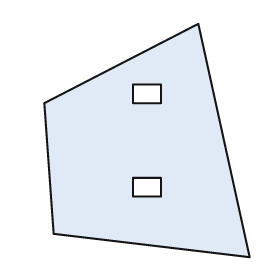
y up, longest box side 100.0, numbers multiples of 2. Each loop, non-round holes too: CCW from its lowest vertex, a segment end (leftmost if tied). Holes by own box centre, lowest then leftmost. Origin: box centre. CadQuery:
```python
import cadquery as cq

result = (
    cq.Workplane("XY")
    .moveTo(44.0, -50.0)
    .lineTo(22.0, 50.0)
    .lineTo(-44.0, 16.0)
    .lineTo(-40.0, -40.0)
    .close()
    .moveTo(-6.0, -24.0)
    .lineTo(6.0, -24.0)
    .lineTo(6.0, -16.0)
    .lineTo(-6.0, -16.0)
    .close()
    .moveTo(-6.0, 16.0)
    .lineTo(6.0, 16.0)
    .lineTo(6.0, 24.0)
    .lineTo(-6.0, 24.0)
    .close()
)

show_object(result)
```